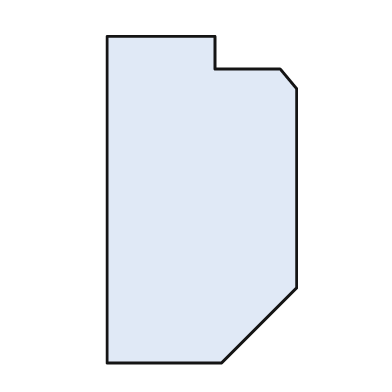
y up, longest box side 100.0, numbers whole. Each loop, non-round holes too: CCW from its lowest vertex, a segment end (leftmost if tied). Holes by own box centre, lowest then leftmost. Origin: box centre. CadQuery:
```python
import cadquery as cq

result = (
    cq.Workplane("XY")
    .moveTo(-29.0, -50.0)
    .lineTo(6.0, -50.0)
    .lineTo(29.0, -27.0)
    .lineTo(29.0, 34.0)
    .lineTo(24.0, 40.0)
    .lineTo(4.0, 40.0)
    .lineTo(4.0, 50.0)
    .lineTo(-29.0, 50.0)
    .close()
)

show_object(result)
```